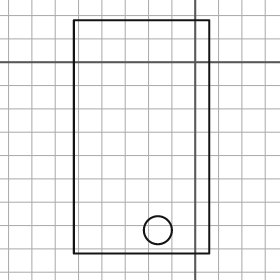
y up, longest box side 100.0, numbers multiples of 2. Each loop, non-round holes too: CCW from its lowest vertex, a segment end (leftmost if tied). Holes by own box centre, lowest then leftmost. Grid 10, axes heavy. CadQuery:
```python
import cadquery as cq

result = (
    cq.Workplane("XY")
    .moveTo(-52.0, -82.0)
    .lineTo(6.0, -82.0)
    .lineTo(6.0, 18.0)
    .lineTo(-52.0, 18.0)
    .close()
    .moveTo(-16.0, -72.0)
    .circle(6.0)
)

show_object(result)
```